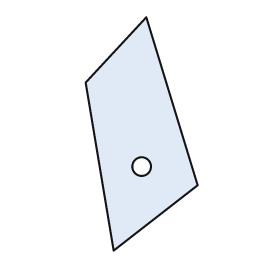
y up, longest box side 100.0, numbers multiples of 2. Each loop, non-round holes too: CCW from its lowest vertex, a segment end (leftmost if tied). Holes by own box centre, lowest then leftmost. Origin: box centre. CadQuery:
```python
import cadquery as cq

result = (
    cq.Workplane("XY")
    .moveTo(-12.0, -50.0)
    .lineTo(24.0, -22.0)
    .lineTo(2.0, 50.0)
    .lineTo(-24.0, 22.0)
    .close()
    .moveTo(0.0, -14.0)
    .circle(4.0)
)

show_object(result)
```